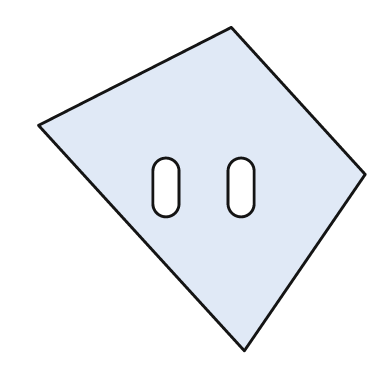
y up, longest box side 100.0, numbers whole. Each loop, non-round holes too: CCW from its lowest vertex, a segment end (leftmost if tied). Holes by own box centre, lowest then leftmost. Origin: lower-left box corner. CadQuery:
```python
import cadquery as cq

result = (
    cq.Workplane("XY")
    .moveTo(63.0, 0.0)
    .lineTo(100.0, 54.0)
    .lineTo(59.0, 99.0)
    .lineTo(0.0, 69.0)
    .close()
    .moveTo(35.0, 45.0)
    .threePointArc((39.0, 41.0), (43.0, 45.0))
    .lineTo(43.0, 55.0)
    .threePointArc((39.0, 59.0), (35.0, 55.0))
    .close()
    .moveTo(58.0, 45.0)
    .threePointArc((62.0, 41.0), (66.0, 45.0))
    .lineTo(66.0, 55.0)
    .threePointArc((62.0, 59.0), (58.0, 55.0))
    .close()
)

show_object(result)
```